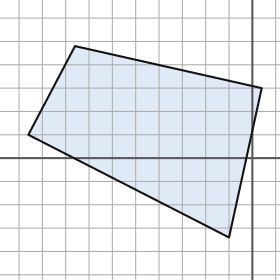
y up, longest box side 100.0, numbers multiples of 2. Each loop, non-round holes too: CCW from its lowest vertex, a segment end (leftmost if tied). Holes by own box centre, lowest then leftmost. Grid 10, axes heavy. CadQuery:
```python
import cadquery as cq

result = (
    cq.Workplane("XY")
    .moveTo(-10.0, -34.0)
    .lineTo(4.0, 30.0)
    .lineTo(-76.0, 48.0)
    .lineTo(-96.0, 10.0)
    .close()
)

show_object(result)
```